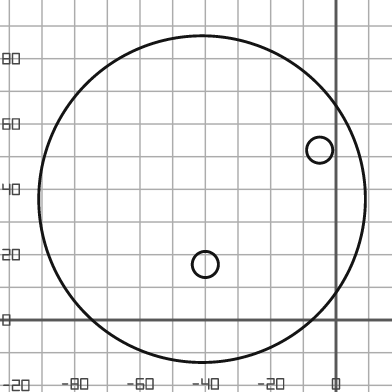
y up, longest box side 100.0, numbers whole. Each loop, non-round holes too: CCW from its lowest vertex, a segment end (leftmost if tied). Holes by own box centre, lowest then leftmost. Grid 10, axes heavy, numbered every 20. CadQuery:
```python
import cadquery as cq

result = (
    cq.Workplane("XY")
    .moveTo(-41.0, 37.0)
    .circle(50.0)
    .moveTo(-40.0, 17.0)
    .circle(4.0)
    .moveTo(-5.0, 52.0)
    .circle(4.0)
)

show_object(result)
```